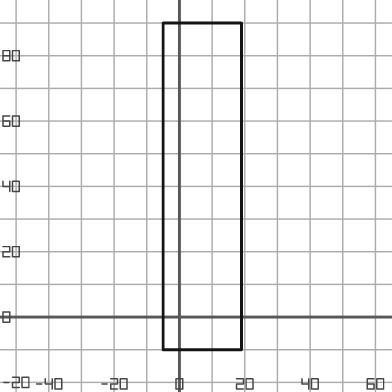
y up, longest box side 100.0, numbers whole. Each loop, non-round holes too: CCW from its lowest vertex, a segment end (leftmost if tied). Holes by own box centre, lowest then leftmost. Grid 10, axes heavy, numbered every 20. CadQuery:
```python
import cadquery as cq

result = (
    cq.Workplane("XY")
    .moveTo(-5.0, -10.0)
    .lineTo(19.0, -10.0)
    .lineTo(19.0, 90.0)
    .lineTo(-5.0, 90.0)
    .close()
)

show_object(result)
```